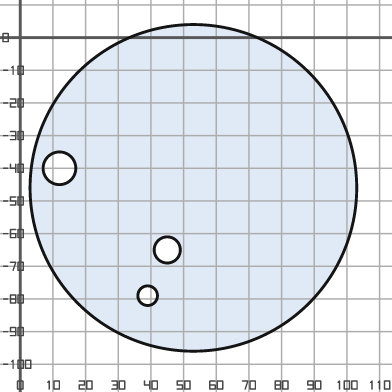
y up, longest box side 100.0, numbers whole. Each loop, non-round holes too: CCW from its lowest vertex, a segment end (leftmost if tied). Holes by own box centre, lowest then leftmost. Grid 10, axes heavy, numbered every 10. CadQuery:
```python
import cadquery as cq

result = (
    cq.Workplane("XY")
    .moveTo(53.0, -46.0)
    .circle(50.0)
    .moveTo(39.0, -79.0)
    .circle(3.0)
    .moveTo(45.0, -65.0)
    .circle(4.0)
    .moveTo(12.0, -40.0)
    .circle(5.0)
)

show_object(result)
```